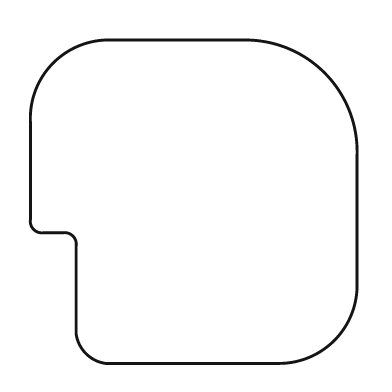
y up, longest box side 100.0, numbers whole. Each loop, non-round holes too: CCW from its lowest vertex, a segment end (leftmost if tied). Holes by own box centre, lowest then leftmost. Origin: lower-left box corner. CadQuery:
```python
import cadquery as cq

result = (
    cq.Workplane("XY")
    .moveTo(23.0, 0.0)
    .lineTo(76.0, 0.0)
    .threePointArc((93.0, 7.0), (100.0, 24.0))
    .lineTo(100.0, 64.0)
    .threePointArc((90.0, 89.0), (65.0, 99.0))
    .lineTo(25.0, 99.0)
    .threePointArc((7.0, 92.0), (0.0, 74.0))
    .lineTo(0.0, 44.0)
    .threePointArc((1.0, 41.0), (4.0, 40.0))
    .lineTo(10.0, 40.0)
    .threePointArc((13.0, 39.0), (14.0, 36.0))
    .lineTo(14.0, 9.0)
    .threePointArc((17.0, 3.0), (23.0, 0.0))
    .close()
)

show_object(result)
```